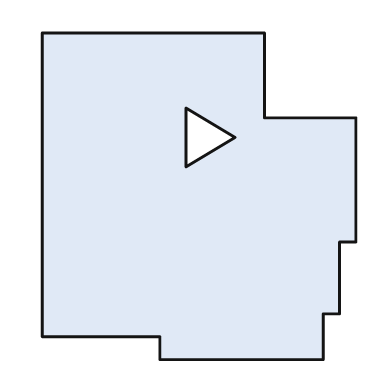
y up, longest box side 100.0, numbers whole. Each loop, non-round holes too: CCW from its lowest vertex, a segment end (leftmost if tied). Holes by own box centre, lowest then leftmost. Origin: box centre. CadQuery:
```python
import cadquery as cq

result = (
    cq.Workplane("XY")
    .moveTo(-12.0, -50.0)
    .lineTo(38.0, -50.0)
    .lineTo(38.0, -36.0)
    .lineTo(43.0, -36.0)
    .lineTo(43.0, -14.0)
    .lineTo(48.0, -14.0)
    .lineTo(48.0, 24.0)
    .lineTo(20.0, 24.0)
    .lineTo(20.0, 50.0)
    .lineTo(-48.0, 50.0)
    .lineTo(-48.0, -43.0)
    .lineTo(-12.0, -43.0)
    .close()
    .moveTo(-4.0, 9.0)
    .lineTo(11.0, 18.0)
    .lineTo(-4.0, 27.0)
    .close()
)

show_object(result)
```